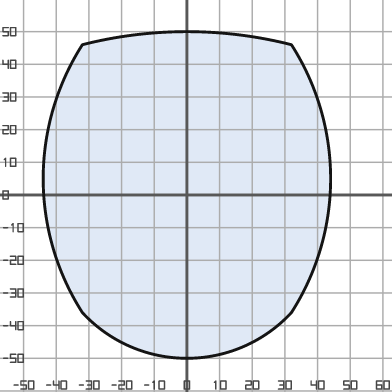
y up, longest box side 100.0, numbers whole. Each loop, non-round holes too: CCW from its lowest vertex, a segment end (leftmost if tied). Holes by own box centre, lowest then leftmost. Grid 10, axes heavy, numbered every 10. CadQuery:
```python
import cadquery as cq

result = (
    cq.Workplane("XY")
    .moveTo(-32.0, -36.0)
    .threePointArc((0.0, -50.0), (32.0, -36.0))
    .threePointArc((44.0, 5.0), (32.0, 46.0))
    .threePointArc((0.0, 50.0), (-32.0, 46.0))
    .threePointArc((-44.0, 5.0), (-32.0, -36.0))
    .close()
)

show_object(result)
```